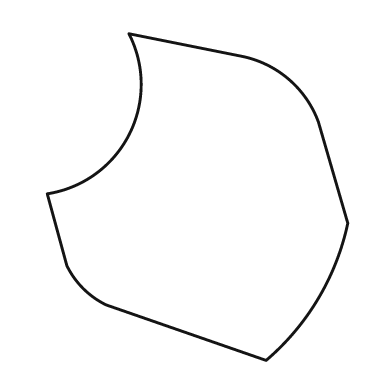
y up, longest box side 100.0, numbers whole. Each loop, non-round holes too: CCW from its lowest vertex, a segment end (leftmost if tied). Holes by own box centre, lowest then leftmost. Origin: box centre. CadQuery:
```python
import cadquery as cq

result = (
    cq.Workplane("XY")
    .moveTo(21.0, -50.0)
    .threePointArc((37.0, -31.0), (46.0, -8.0))
    .lineTo(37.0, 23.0)
    .threePointArc((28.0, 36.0), (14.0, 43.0))
    .lineTo(-21.0, 50.0)
    .threePointArc((-21.0, 19.0), (-46.0, 1.0))
    .lineTo(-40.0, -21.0)
    .threePointArc((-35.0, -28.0), (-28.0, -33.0))
    .close()
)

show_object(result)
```